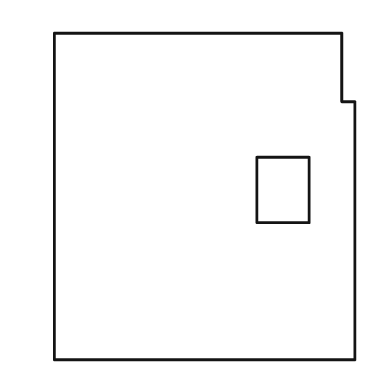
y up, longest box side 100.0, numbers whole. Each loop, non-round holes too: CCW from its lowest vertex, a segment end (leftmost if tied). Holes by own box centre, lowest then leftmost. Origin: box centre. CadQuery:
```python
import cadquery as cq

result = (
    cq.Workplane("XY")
    .moveTo(-46.0, -50.0)
    .lineTo(46.0, -50.0)
    .lineTo(46.0, 29.0)
    .lineTo(42.0, 29.0)
    .lineTo(42.0, 50.0)
    .lineTo(-46.0, 50.0)
    .close()
    .moveTo(16.0, -8.0)
    .lineTo(32.0, -8.0)
    .lineTo(32.0, 12.0)
    .lineTo(16.0, 12.0)
    .close()
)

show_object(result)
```